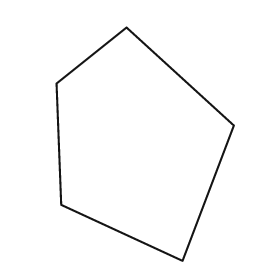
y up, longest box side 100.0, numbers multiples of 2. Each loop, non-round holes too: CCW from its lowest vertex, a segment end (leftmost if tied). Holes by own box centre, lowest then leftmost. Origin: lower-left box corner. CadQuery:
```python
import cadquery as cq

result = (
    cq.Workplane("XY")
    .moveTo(54.0, 0.0)
    .lineTo(76.0, 58.0)
    .lineTo(30.0, 100.0)
    .lineTo(0.0, 76.0)
    .lineTo(2.0, 24.0)
    .close()
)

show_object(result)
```